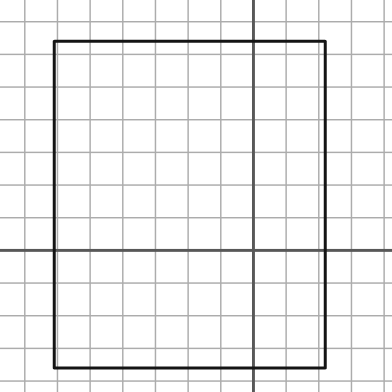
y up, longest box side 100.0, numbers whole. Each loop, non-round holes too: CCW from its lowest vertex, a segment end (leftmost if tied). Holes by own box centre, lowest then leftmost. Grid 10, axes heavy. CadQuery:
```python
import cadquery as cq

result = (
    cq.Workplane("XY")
    .moveTo(-61.0, -36.0)
    .lineTo(22.0, -36.0)
    .lineTo(22.0, 64.0)
    .lineTo(-61.0, 64.0)
    .close()
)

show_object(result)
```